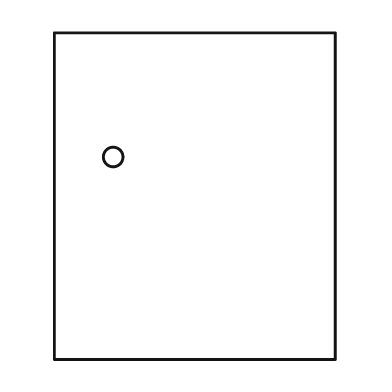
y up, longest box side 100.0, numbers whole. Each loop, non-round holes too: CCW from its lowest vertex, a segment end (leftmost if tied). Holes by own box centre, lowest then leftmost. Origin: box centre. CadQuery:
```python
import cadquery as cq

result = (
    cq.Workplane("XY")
    .moveTo(-43.0, -50.0)
    .lineTo(43.0, -50.0)
    .lineTo(43.0, 50.0)
    .lineTo(-43.0, 50.0)
    .close()
    .moveTo(-25.0, 12.0)
    .circle(3.0)
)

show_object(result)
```